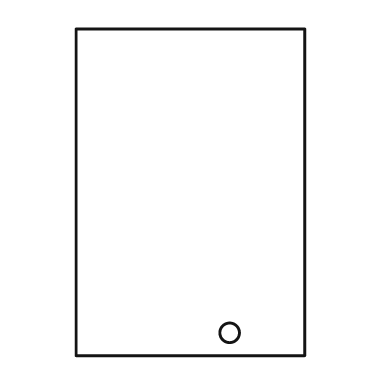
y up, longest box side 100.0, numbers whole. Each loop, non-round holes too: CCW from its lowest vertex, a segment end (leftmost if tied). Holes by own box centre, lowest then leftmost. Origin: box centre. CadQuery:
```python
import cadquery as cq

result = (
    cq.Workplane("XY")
    .moveTo(-35.0, -50.0)
    .lineTo(35.0, -50.0)
    .lineTo(35.0, 50.0)
    .lineTo(-35.0, 50.0)
    .close()
    .moveTo(12.0, -43.0)
    .circle(3.0)
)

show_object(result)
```